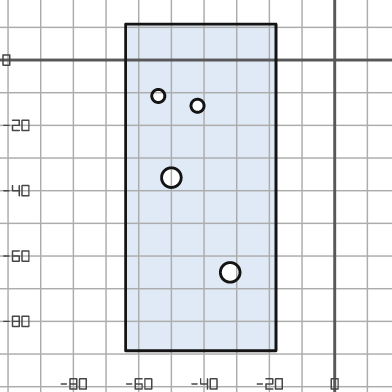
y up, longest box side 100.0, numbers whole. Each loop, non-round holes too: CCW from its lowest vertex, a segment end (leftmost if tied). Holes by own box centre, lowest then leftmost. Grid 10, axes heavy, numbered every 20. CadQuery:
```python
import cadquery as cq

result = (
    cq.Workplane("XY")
    .moveTo(-64.0, -89.0)
    .lineTo(-18.0, -89.0)
    .lineTo(-18.0, 11.0)
    .lineTo(-64.0, 11.0)
    .close()
    .moveTo(-32.0, -65.0)
    .circle(3.0)
    .moveTo(-50.0, -36.0)
    .circle(3.0)
    .moveTo(-42.0, -14.0)
    .circle(2.0)
    .moveTo(-54.0, -11.0)
    .circle(2.0)
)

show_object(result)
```